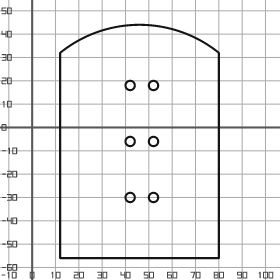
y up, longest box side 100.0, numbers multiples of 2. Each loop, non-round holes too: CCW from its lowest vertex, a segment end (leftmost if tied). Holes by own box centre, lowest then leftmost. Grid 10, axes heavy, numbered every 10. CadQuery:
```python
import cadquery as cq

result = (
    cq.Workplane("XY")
    .moveTo(12.0, -56.0)
    .lineTo(80.0, -56.0)
    .lineTo(80.0, 32.0)
    .threePointArc((46.0, 44.0), (12.0, 32.0))
    .close()
    .moveTo(42.0, -30.0)
    .circle(2.0)
    .moveTo(52.0, -30.0)
    .circle(2.0)
    .moveTo(42.0, -6.0)
    .circle(2.0)
    .moveTo(52.0, -6.0)
    .circle(2.0)
    .moveTo(42.0, 18.0)
    .circle(2.0)
    .moveTo(52.0, 18.0)
    .circle(2.0)
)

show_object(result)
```